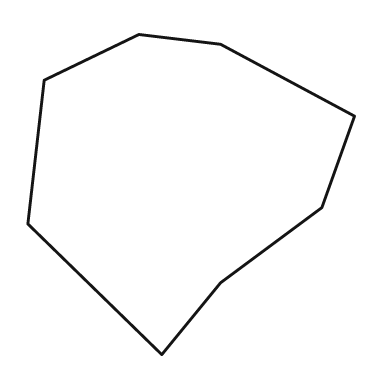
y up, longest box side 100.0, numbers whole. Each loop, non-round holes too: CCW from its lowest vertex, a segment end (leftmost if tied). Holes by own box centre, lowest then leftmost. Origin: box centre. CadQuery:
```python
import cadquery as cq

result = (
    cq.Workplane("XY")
    .moveTo(-9.0, -49.0)
    .lineTo(9.0, -27.0)
    .lineTo(40.0, -4.0)
    .lineTo(50.0, 24.0)
    .lineTo(9.0, 46.0)
    .lineTo(-16.0, 49.0)
    .lineTo(-45.0, 35.0)
    .lineTo(-50.0, -9.0)
    .close()
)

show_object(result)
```